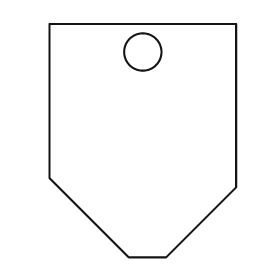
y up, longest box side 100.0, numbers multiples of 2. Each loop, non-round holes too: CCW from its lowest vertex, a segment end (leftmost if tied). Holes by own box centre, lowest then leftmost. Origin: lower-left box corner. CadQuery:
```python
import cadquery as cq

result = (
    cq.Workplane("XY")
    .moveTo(34.0, 0.0)
    .lineTo(50.0, 0.0)
    .lineTo(80.0, 30.0)
    .lineTo(80.0, 100.0)
    .lineTo(0.0, 100.0)
    .lineTo(0.0, 34.0)
    .close()
    .moveTo(40.0, 88.0)
    .circle(8.0)
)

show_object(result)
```